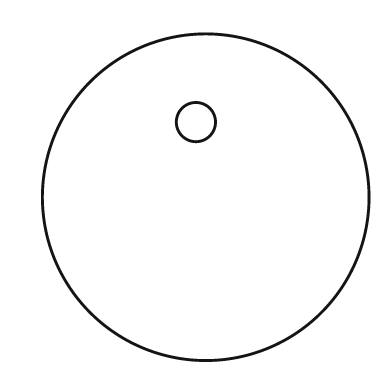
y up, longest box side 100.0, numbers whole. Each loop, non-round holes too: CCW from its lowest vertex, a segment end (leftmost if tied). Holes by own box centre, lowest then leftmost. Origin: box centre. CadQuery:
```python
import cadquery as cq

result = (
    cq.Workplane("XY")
    .moveTo(0.0, 0.0)
    .circle(50.0)
    .moveTo(-3.0, 23.0)
    .circle(6.0)
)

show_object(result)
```